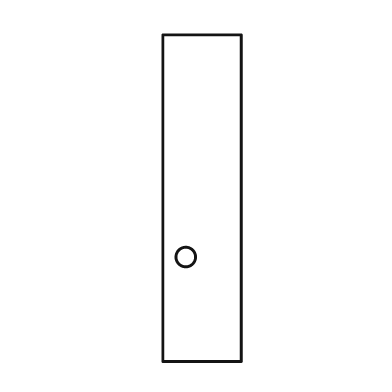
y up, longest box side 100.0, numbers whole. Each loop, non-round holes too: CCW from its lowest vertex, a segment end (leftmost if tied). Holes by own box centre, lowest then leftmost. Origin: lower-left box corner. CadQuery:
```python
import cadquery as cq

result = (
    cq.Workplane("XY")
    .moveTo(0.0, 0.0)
    .lineTo(24.0, 0.0)
    .lineTo(24.0, 100.0)
    .lineTo(0.0, 100.0)
    .close()
    .moveTo(7.0, 32.0)
    .circle(3.0)
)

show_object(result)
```